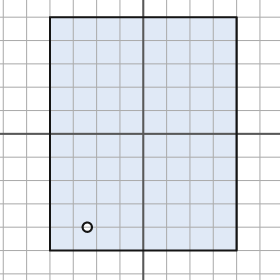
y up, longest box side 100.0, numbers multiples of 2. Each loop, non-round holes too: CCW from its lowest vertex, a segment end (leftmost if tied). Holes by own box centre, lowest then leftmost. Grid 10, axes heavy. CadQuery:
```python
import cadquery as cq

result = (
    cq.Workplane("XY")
    .moveTo(-40.0, -50.0)
    .lineTo(40.0, -50.0)
    .lineTo(40.0, 50.0)
    .lineTo(-40.0, 50.0)
    .close()
    .moveTo(-24.0, -40.0)
    .circle(2.0)
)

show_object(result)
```